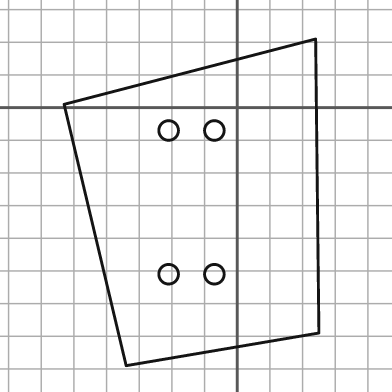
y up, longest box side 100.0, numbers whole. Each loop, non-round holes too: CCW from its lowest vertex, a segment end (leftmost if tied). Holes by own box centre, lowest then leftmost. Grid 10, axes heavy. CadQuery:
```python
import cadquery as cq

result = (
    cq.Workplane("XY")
    .moveTo(-34.0, -79.0)
    .lineTo(25.0, -69.0)
    .lineTo(24.0, 21.0)
    .lineTo(-53.0, 1.0)
    .close()
    .moveTo(-21.0, -51.0)
    .circle(3.0)
    .moveTo(-7.0, -51.0)
    .circle(3.0)
    .moveTo(-21.0, -7.0)
    .circle(3.0)
    .moveTo(-7.0, -7.0)
    .circle(3.0)
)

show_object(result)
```